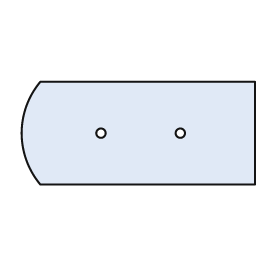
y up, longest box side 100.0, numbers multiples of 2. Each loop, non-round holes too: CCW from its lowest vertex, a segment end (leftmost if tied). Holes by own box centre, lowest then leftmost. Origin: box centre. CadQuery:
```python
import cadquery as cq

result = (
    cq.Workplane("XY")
    .moveTo(-42.0, -22.0)
    .lineTo(50.0, -22.0)
    .lineTo(50.0, 22.0)
    .lineTo(-42.0, 22.0)
    .threePointArc((-50.0, 0.0), (-42.0, -22.0))
    .close()
    .moveTo(-16.0, 0.0)
    .circle(2.0)
    .moveTo(18.0, 0.0)
    .circle(2.0)
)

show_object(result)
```